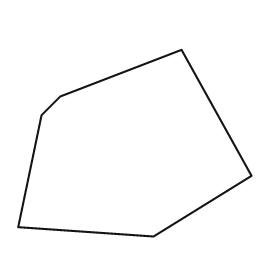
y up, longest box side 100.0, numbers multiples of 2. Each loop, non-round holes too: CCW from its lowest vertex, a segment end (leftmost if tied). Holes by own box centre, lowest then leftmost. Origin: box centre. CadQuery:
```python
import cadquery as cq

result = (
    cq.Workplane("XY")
    .moveTo(8.0, -40.0)
    .lineTo(50.0, -14.0)
    .lineTo(20.0, 40.0)
    .lineTo(-32.0, 20.0)
    .lineTo(-40.0, 12.0)
    .lineTo(-50.0, -36.0)
    .close()
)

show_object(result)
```